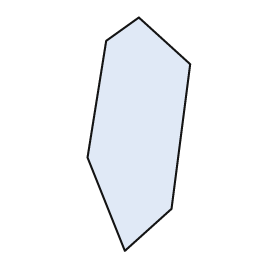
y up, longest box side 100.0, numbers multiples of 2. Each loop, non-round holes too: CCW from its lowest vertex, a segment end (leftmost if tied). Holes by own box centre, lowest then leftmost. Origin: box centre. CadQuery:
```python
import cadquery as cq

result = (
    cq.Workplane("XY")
    .moveTo(-6.0, -50.0)
    .lineTo(14.0, -32.0)
    .lineTo(22.0, 30.0)
    .lineTo(0.0, 50.0)
    .lineTo(-14.0, 40.0)
    .lineTo(-22.0, -10.0)
    .close()
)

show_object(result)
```